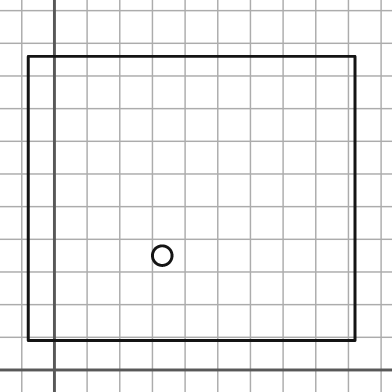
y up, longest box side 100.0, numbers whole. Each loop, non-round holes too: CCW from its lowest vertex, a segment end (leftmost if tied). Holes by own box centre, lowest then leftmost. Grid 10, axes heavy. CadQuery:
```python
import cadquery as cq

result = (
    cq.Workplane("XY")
    .moveTo(-8.0, 9.0)
    .lineTo(92.0, 9.0)
    .lineTo(92.0, 96.0)
    .lineTo(-8.0, 96.0)
    .close()
    .moveTo(33.0, 35.0)
    .circle(3.0)
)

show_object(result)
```